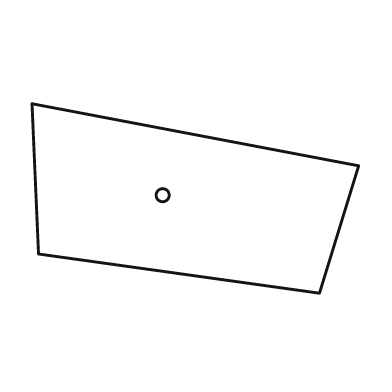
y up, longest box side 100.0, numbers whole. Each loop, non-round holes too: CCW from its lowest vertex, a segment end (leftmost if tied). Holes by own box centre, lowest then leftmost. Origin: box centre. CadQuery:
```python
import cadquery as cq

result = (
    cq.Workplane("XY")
    .moveTo(38.0, -29.0)
    .lineTo(50.0, 10.0)
    .lineTo(-50.0, 29.0)
    .lineTo(-48.0, -17.0)
    .close()
    .moveTo(-10.0, 1.0)
    .circle(2.0)
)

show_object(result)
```